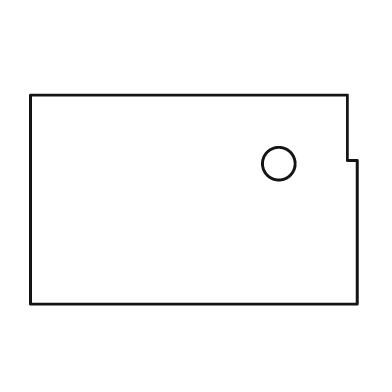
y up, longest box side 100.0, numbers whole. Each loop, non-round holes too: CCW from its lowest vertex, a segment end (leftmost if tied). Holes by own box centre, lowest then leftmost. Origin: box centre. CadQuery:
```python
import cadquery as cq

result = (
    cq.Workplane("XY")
    .moveTo(-50.0, -32.0)
    .lineTo(50.0, -32.0)
    .lineTo(50.0, 12.0)
    .lineTo(47.0, 12.0)
    .lineTo(47.0, 32.0)
    .lineTo(-50.0, 32.0)
    .close()
    .moveTo(26.0, 11.0)
    .circle(5.0)
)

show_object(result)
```